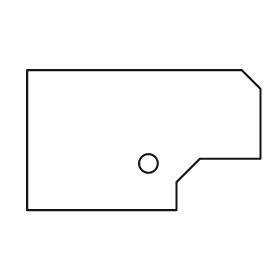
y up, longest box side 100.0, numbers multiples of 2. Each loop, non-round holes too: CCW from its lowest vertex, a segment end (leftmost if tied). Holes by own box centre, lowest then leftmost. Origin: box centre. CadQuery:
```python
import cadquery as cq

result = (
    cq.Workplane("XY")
    .moveTo(-50.0, -30.0)
    .lineTo(14.0, -30.0)
    .lineTo(14.0, -18.0)
    .lineTo(24.0, -8.0)
    .lineTo(50.0, -8.0)
    .lineTo(50.0, 22.0)
    .lineTo(42.0, 30.0)
    .lineTo(-50.0, 30.0)
    .close()
    .moveTo(2.0, -10.0)
    .circle(4.0)
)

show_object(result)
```